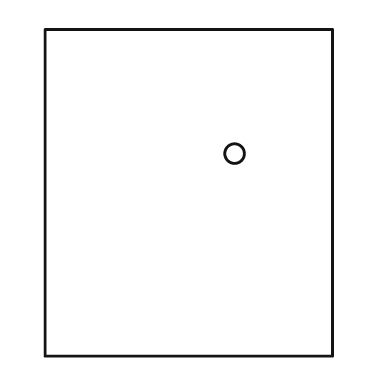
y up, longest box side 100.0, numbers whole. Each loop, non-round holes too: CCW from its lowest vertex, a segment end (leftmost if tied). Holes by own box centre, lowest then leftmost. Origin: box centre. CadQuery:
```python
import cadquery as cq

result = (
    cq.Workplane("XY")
    .moveTo(-44.0, -50.0)
    .lineTo(44.0, -50.0)
    .lineTo(44.0, 50.0)
    .lineTo(-44.0, 50.0)
    .close()
    .moveTo(14.0, 12.0)
    .circle(3.0)
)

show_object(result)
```